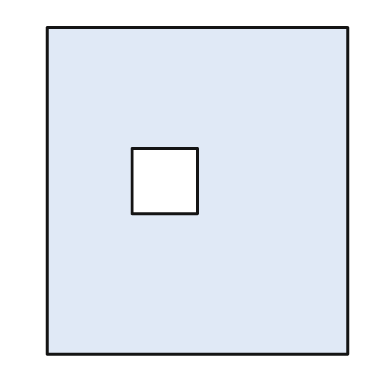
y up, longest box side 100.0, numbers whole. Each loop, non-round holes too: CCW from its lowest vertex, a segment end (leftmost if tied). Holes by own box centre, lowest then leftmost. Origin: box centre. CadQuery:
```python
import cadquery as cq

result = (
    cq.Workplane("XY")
    .moveTo(-46.0, -50.0)
    .lineTo(46.0, -50.0)
    .lineTo(46.0, 50.0)
    .lineTo(-46.0, 50.0)
    .close()
    .moveTo(-20.0, -7.0)
    .lineTo(0.0, -7.0)
    .lineTo(0.0, 13.0)
    .lineTo(-20.0, 13.0)
    .close()
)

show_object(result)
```